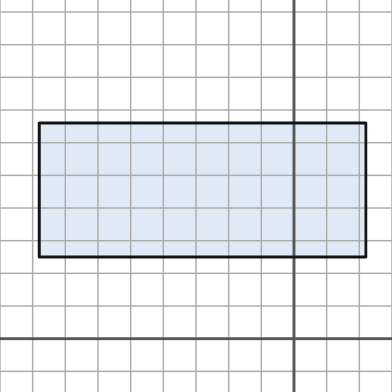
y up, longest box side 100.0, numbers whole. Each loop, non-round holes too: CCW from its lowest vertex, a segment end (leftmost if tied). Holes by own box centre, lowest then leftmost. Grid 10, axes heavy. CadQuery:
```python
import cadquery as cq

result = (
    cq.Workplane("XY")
    .moveTo(-78.0, 25.0)
    .lineTo(22.0, 25.0)
    .lineTo(22.0, 66.0)
    .lineTo(-78.0, 66.0)
    .close()
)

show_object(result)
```